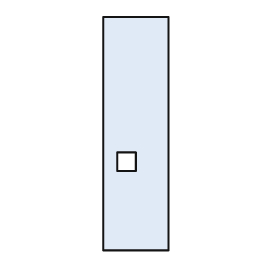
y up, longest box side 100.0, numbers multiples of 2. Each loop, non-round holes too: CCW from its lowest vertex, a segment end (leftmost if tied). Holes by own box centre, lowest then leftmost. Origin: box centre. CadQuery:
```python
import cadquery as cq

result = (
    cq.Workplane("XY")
    .moveTo(-14.0, -50.0)
    .lineTo(14.0, -50.0)
    .lineTo(14.0, 50.0)
    .lineTo(-14.0, 50.0)
    .close()
    .moveTo(-8.0, -16.0)
    .lineTo(0.0, -16.0)
    .lineTo(0.0, -8.0)
    .lineTo(-8.0, -8.0)
    .close()
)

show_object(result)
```